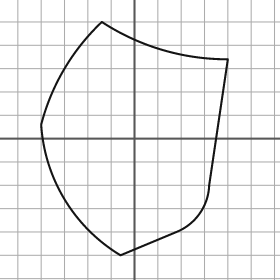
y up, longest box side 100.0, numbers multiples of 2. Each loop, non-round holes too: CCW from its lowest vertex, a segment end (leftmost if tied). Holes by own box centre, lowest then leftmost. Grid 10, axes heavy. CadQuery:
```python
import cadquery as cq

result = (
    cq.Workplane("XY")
    .moveTo(-6.0, -50.0)
    .lineTo(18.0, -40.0)
    .threePointArc((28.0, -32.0), (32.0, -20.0))
    .lineTo(40.0, 34.0)
    .threePointArc((12.0, 38.0), (-14.0, 50.0))
    .threePointArc((-30.0, 30.0), (-40.0, 6.0))
    .threePointArc((-30.0, -26.0), (-6.0, -50.0))
    .close()
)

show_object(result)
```